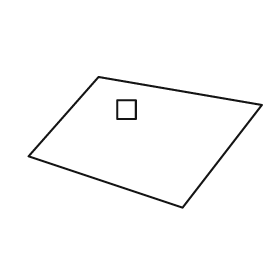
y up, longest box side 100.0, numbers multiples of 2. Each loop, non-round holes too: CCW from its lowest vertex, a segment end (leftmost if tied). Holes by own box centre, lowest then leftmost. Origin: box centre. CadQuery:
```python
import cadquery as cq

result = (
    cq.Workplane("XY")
    .moveTo(16.0, -28.0)
    .lineTo(50.0, 16.0)
    .lineTo(-20.0, 28.0)
    .lineTo(-50.0, -6.0)
    .close()
    .moveTo(-12.0, 10.0)
    .lineTo(-4.0, 10.0)
    .lineTo(-4.0, 18.0)
    .lineTo(-12.0, 18.0)
    .close()
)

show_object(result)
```